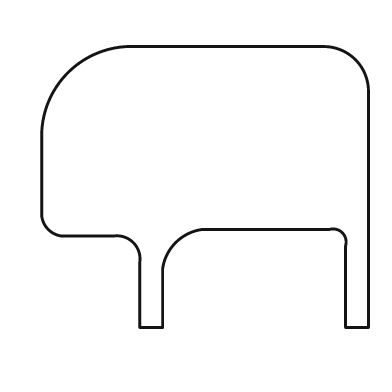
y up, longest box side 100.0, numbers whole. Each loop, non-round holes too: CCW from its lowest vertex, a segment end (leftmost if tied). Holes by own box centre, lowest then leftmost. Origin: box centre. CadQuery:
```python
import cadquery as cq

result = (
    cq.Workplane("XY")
    .moveTo(-20.0, -43.0)
    .lineTo(-13.0, -43.0)
    .lineTo(-13.0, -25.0)
    .threePointArc((-9.0, -17.0), (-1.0, -13.0))
    .lineTo(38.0, -13.0)
    .threePointArc((42.0, -14.0), (43.0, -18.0))
    .lineTo(43.0, -43.0)
    .lineTo(50.0, -43.0)
    .lineTo(50.0, 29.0)
    .threePointArc((46.0, 39.0), (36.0, 43.0))
    .lineTo(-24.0, 43.0)
    .threePointArc((-42.0, 35.0), (-50.0, 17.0))
    .lineTo(-50.0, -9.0)
    .threePointArc((-48.0, -13.0), (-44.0, -15.0))
    .lineTo(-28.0, -15.0)
    .threePointArc((-22.0, -17.0), (-20.0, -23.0))
    .close()
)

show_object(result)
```